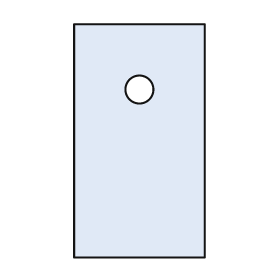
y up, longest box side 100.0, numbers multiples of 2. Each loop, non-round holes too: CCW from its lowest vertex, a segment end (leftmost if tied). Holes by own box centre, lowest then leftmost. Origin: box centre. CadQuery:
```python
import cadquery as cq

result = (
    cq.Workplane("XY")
    .moveTo(-28.0, -50.0)
    .lineTo(28.0, -50.0)
    .lineTo(28.0, 50.0)
    .lineTo(-28.0, 50.0)
    .close()
    .moveTo(0.0, 22.0)
    .circle(6.0)
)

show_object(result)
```